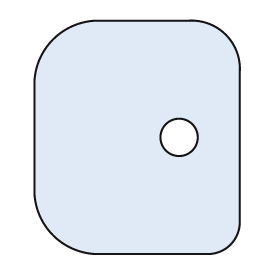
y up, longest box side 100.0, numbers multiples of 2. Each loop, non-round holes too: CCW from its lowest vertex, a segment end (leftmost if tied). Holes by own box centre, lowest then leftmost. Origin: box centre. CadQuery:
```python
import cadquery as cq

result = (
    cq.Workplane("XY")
    .moveTo(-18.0, -50.0)
    .lineTo(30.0, -50.0)
    .threePointArc((40.0, -46.0), (44.0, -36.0))
    .lineTo(44.0, 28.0)
    .threePointArc((38.0, 44.0), (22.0, 50.0))
    .lineTo(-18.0, 50.0)
    .threePointArc((-36.0, 42.0), (-44.0, 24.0))
    .lineTo(-44.0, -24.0)
    .threePointArc((-36.0, -42.0), (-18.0, -50.0))
    .close()
    .moveTo(18.0, 0.0)
    .circle(8.0)
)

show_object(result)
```